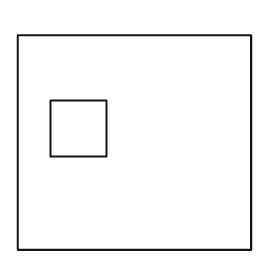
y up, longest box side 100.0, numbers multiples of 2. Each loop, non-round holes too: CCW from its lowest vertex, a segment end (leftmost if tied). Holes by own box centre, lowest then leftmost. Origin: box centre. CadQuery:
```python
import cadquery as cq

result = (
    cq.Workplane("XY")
    .moveTo(-50.0, -46.0)
    .lineTo(50.0, -46.0)
    .lineTo(50.0, 46.0)
    .lineTo(-50.0, 46.0)
    .close()
    .moveTo(-36.0, -6.0)
    .lineTo(-12.0, -6.0)
    .lineTo(-12.0, 18.0)
    .lineTo(-36.0, 18.0)
    .close()
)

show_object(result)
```